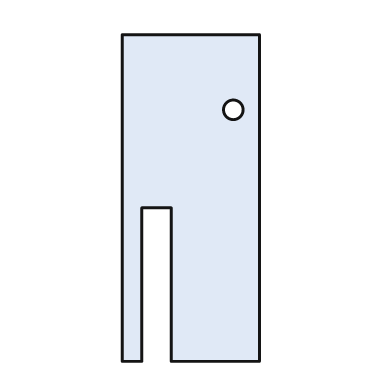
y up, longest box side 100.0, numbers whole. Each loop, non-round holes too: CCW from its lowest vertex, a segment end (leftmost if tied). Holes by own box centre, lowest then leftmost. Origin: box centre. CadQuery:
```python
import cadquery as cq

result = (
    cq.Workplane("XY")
    .moveTo(-21.0, -50.0)
    .lineTo(-15.0, -50.0)
    .lineTo(-15.0, -3.0)
    .lineTo(-6.0, -3.0)
    .lineTo(-6.0, -50.0)
    .lineTo(21.0, -50.0)
    .lineTo(21.0, 50.0)
    .lineTo(-21.0, 50.0)
    .close()
    .moveTo(13.0, 27.0)
    .circle(3.0)
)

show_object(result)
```